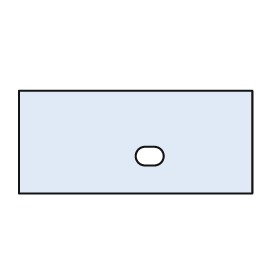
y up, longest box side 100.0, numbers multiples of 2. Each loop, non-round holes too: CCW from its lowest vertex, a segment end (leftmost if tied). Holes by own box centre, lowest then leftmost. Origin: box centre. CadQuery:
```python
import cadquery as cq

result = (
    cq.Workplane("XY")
    .moveTo(-50.0, -22.0)
    .lineTo(50.0, -22.0)
    .lineTo(50.0, 22.0)
    .lineTo(-50.0, 22.0)
    .close()
    .moveTo(4.0, -10.0)
    .lineTo(8.0, -10.0)
    .threePointArc((12.0, -6.0), (8.0, -2.0))
    .lineTo(4.0, -2.0)
    .threePointArc((0.0, -6.0), (4.0, -10.0))
    .close()
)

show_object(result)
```